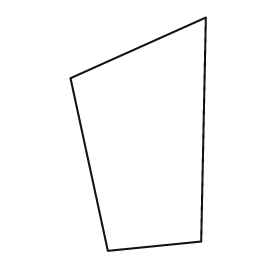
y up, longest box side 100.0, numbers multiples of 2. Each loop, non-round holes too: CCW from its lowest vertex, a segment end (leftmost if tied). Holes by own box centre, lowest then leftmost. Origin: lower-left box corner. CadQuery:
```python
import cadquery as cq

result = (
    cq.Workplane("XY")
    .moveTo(16.0, 0.0)
    .lineTo(56.0, 4.0)
    .lineTo(58.0, 100.0)
    .lineTo(0.0, 74.0)
    .close()
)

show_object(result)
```